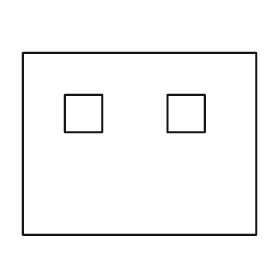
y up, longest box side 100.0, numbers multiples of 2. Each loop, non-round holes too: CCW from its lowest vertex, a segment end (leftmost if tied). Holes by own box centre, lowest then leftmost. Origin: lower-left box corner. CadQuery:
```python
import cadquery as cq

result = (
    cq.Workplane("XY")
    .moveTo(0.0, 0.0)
    .lineTo(100.0, 0.0)
    .lineTo(100.0, 78.0)
    .lineTo(0.0, 78.0)
    .close()
    .moveTo(18.0, 44.0)
    .lineTo(34.0, 44.0)
    .lineTo(34.0, 60.0)
    .lineTo(18.0, 60.0)
    .close()
    .moveTo(62.0, 44.0)
    .lineTo(78.0, 44.0)
    .lineTo(78.0, 60.0)
    .lineTo(62.0, 60.0)
    .close()
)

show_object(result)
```